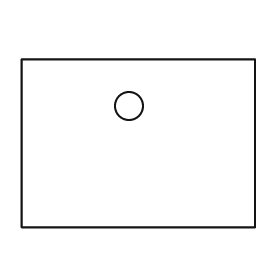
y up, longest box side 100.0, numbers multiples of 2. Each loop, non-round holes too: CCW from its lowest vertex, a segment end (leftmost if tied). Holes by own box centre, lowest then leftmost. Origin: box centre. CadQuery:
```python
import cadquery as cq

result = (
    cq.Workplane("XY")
    .moveTo(-50.0, -36.0)
    .lineTo(50.0, -36.0)
    .lineTo(50.0, 36.0)
    .lineTo(-50.0, 36.0)
    .close()
    .moveTo(-4.0, 16.0)
    .circle(6.0)
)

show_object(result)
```